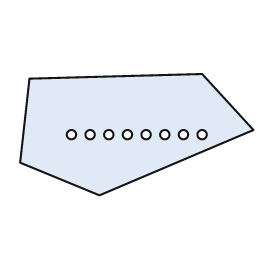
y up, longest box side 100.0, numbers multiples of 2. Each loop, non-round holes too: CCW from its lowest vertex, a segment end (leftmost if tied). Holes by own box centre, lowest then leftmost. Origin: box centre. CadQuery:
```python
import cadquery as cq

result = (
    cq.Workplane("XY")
    .moveTo(-16.0, -26.0)
    .lineTo(50.0, 2.0)
    .lineTo(28.0, 26.0)
    .lineTo(-46.0, 24.0)
    .lineTo(-50.0, -12.0)
    .close()
    .moveTo(-28.0, 0.0)
    .circle(2.0)
    .moveTo(-20.0, 0.0)
    .circle(2.0)
    .moveTo(-12.0, 0.0)
    .circle(2.0)
    .moveTo(-4.0, 0.0)
    .circle(2.0)
    .moveTo(4.0, 0.0)
    .circle(2.0)
    .moveTo(12.0, 0.0)
    .circle(2.0)
    .moveTo(20.0, 0.0)
    .circle(2.0)
    .moveTo(28.0, 0.0)
    .circle(2.0)
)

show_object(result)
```